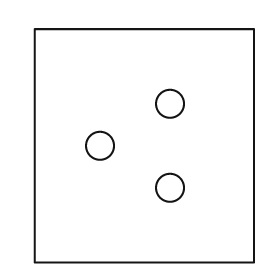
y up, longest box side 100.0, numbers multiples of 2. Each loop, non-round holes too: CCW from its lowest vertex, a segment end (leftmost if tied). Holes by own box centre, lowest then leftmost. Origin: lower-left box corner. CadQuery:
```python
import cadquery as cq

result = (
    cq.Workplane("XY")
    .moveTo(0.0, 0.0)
    .lineTo(94.0, 0.0)
    .lineTo(94.0, 100.0)
    .lineTo(0.0, 100.0)
    .close()
    .moveTo(58.0, 32.0)
    .circle(6.0)
    .moveTo(28.0, 50.0)
    .circle(6.0)
    .moveTo(58.0, 68.0)
    .circle(6.0)
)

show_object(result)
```